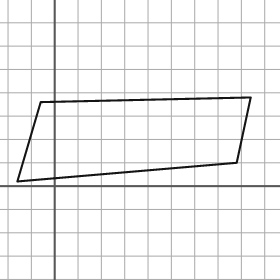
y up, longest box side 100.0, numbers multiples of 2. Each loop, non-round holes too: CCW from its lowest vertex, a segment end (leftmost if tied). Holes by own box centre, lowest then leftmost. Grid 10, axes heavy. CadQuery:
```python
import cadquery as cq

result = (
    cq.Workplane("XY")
    .moveTo(-16.0, 2.0)
    .lineTo(78.0, 10.0)
    .lineTo(84.0, 38.0)
    .lineTo(-6.0, 36.0)
    .close()
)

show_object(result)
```